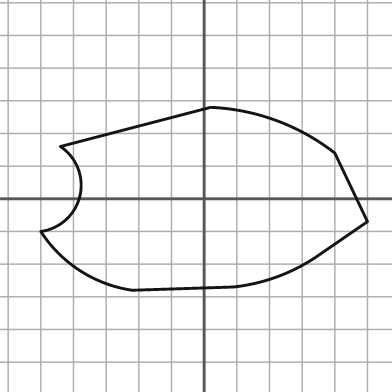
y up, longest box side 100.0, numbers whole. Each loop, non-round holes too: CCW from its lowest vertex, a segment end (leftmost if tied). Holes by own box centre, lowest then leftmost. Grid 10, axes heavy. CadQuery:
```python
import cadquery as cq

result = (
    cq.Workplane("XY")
    .moveTo(-22.0, -28.0)
    .lineTo(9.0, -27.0)
    .threePointArc((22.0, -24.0), (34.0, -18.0))
    .lineTo(50.0, -7.0)
    .lineTo(40.0, 14.0)
    .threePointArc((22.0, 24.0), (2.0, 28.0))
    .lineTo(-44.0, 16.0)
    .threePointArc((-38.0, 1.0), (-50.0, -10.0))
    .threePointArc((-38.0, -22.0), (-22.0, -28.0))
    .close()
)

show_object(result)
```